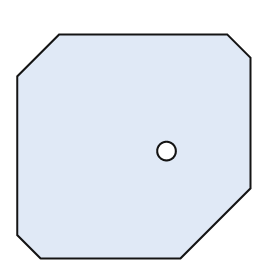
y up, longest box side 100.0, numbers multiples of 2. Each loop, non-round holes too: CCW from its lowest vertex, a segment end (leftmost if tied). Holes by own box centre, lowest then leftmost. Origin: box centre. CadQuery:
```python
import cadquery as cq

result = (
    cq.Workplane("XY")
    .moveTo(-40.0, -48.0)
    .lineTo(20.0, -48.0)
    .lineTo(50.0, -18.0)
    .lineTo(50.0, 38.0)
    .lineTo(40.0, 48.0)
    .lineTo(-32.0, 48.0)
    .lineTo(-50.0, 30.0)
    .lineTo(-50.0, -38.0)
    .close()
    .moveTo(14.0, -2.0)
    .circle(4.0)
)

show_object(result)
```